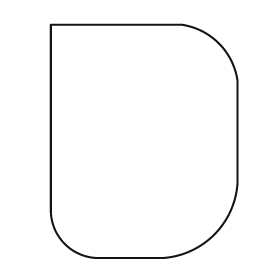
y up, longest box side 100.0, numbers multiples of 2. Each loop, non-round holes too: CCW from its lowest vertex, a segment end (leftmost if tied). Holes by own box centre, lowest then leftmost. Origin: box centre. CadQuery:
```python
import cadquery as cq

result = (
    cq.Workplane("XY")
    .moveTo(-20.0, -50.0)
    .lineTo(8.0, -50.0)
    .threePointArc((30.0, -40.0), (40.0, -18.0))
    .lineTo(40.0, 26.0)
    .threePointArc((32.0, 42.0), (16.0, 50.0))
    .lineTo(-40.0, 50.0)
    .lineTo(-40.0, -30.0)
    .threePointArc((-34.0, -44.0), (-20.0, -50.0))
    .close()
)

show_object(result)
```